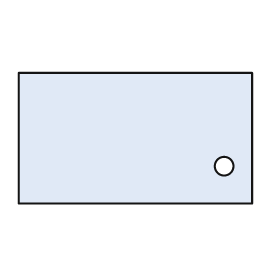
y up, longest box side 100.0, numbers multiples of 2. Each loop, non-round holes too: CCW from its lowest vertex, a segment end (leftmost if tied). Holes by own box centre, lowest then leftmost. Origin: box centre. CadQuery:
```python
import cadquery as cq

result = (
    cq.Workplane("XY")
    .moveTo(-50.0, -28.0)
    .lineTo(50.0, -28.0)
    .lineTo(50.0, 28.0)
    .lineTo(-50.0, 28.0)
    .close()
    .moveTo(38.0, -12.0)
    .circle(4.0)
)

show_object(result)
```